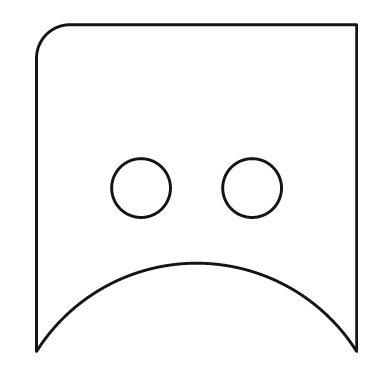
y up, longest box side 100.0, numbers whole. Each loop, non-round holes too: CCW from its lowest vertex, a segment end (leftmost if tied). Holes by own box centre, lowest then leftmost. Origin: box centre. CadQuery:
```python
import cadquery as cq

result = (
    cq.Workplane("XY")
    .moveTo(-49.0, -50.0)
    .threePointArc((0.0, -23.0), (49.0, -50.0))
    .lineTo(49.0, 50.0)
    .lineTo(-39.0, 50.0)
    .threePointArc((-46.0, 47.0), (-49.0, 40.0))
    .close()
    .moveTo(-17.0, 0.0)
    .circle(9.0)
    .moveTo(17.0, 0.0)
    .circle(9.0)
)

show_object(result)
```